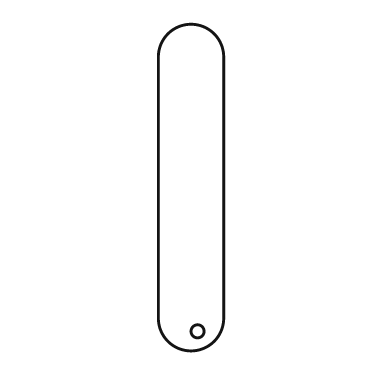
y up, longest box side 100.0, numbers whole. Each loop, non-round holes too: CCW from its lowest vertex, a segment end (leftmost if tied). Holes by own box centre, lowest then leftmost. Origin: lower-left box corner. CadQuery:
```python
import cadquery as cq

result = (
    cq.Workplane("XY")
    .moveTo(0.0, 10.0)
    .threePointArc((10.0, 0.0), (20.0, 10.0))
    .lineTo(20.0, 90.0)
    .threePointArc((10.0, 100.0), (0.0, 90.0))
    .close()
    .moveTo(12.0, 6.0)
    .circle(2.0)
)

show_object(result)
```